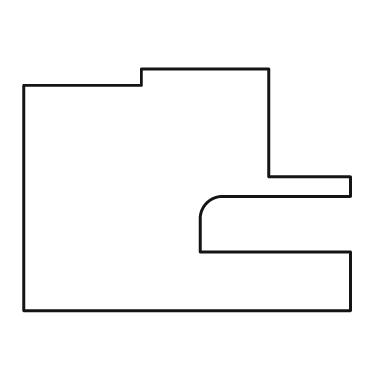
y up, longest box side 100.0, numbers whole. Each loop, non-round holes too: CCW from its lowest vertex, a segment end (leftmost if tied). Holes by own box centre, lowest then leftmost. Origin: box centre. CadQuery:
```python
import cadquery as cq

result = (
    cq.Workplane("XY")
    .moveTo(-50.0, -37.0)
    .lineTo(50.0, -37.0)
    .lineTo(50.0, -19.0)
    .lineTo(4.0, -19.0)
    .lineTo(4.0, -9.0)
    .threePointArc((6.0, -4.0), (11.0, -2.0))
    .lineTo(50.0, -2.0)
    .lineTo(50.0, 4.0)
    .lineTo(25.0, 4.0)
    .lineTo(25.0, 37.0)
    .lineTo(-14.0, 37.0)
    .lineTo(-14.0, 32.0)
    .lineTo(-50.0, 32.0)
    .close()
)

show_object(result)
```